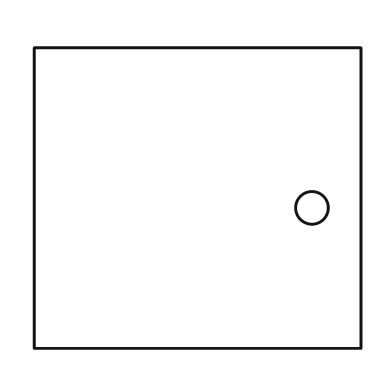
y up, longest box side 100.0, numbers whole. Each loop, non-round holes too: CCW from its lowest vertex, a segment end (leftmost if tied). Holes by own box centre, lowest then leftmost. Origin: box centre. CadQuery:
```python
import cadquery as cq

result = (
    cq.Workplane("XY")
    .moveTo(-50.0, -46.0)
    .lineTo(50.0, -46.0)
    .lineTo(50.0, 46.0)
    .lineTo(-50.0, 46.0)
    .close()
    .moveTo(35.0, -3.0)
    .circle(5.0)
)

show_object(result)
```